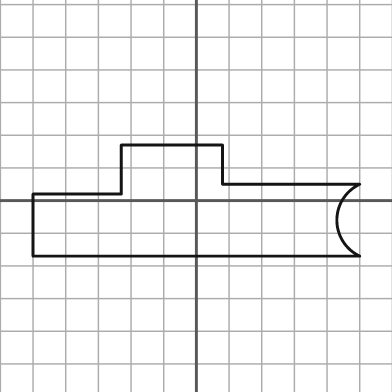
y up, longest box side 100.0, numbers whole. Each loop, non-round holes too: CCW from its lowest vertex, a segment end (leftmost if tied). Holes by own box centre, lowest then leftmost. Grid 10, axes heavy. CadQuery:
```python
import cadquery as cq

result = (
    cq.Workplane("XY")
    .moveTo(-50.0, -17.0)
    .lineTo(50.0, -17.0)
    .threePointArc((43.0, -6.0), (50.0, 5.0))
    .lineTo(8.0, 5.0)
    .lineTo(8.0, 17.0)
    .lineTo(-23.0, 17.0)
    .lineTo(-23.0, 2.0)
    .lineTo(-50.0, 2.0)
    .close()
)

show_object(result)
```